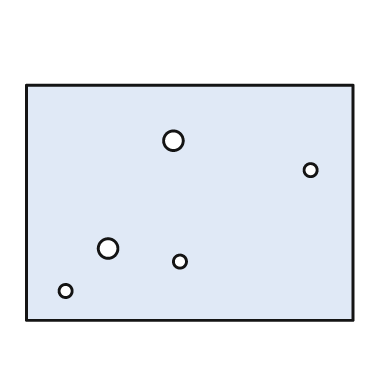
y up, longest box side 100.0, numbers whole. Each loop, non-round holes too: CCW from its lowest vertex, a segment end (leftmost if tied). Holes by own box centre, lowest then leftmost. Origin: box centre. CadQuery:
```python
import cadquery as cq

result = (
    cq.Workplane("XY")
    .moveTo(-50.0, -36.0)
    .lineTo(50.0, -36.0)
    .lineTo(50.0, 36.0)
    .lineTo(-50.0, 36.0)
    .close()
    .moveTo(-38.0, -27.0)
    .circle(2.0)
    .moveTo(-3.0, -18.0)
    .circle(2.0)
    .moveTo(-25.0, -14.0)
    .circle(3.0)
    .moveTo(37.0, 10.0)
    .circle(2.0)
    .moveTo(-5.0, 19.0)
    .circle(3.0)
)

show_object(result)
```